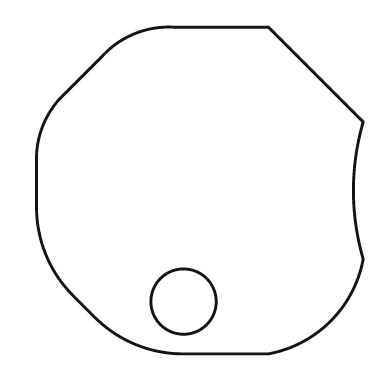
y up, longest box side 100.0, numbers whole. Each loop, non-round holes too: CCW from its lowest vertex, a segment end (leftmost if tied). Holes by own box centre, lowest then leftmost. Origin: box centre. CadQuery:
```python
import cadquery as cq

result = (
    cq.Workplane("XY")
    .moveTo(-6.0, -50.0)
    .lineTo(21.0, -50.0)
    .threePointArc((40.0, -40.0), (50.0, -21.0))
    .threePointArc((47.0, 0.0), (50.0, 21.0))
    .lineTo(21.0, 50.0)
    .lineTo(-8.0, 50.0)
    .threePointArc((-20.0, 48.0), (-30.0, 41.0))
    .lineTo(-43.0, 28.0)
    .threePointArc((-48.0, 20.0), (-50.0, 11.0))
    .lineTo(-50.0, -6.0)
    .threePointArc((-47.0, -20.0), (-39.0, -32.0))
    .lineTo(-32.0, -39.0)
    .threePointArc((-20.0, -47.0), (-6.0, -50.0))
    .close()
    .moveTo(-5.0, -34.0)
    .circle(10.0)
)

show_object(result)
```